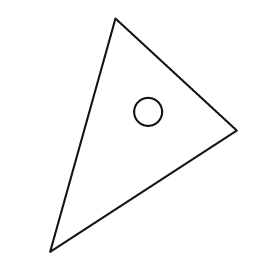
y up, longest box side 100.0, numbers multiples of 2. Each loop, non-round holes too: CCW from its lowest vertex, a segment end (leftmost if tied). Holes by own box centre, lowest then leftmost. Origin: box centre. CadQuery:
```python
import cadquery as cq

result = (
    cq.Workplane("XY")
    .moveTo(-40.0, -50.0)
    .lineTo(40.0, 2.0)
    .lineTo(-12.0, 50.0)
    .close()
    .moveTo(2.0, 10.0)
    .circle(6.0)
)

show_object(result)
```